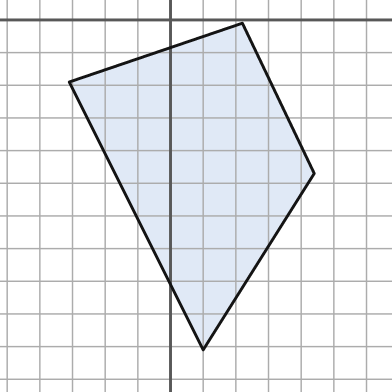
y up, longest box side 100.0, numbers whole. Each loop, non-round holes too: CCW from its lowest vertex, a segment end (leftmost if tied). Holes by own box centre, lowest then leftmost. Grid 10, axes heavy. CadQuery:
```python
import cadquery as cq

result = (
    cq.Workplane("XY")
    .moveTo(10.0, -101.0)
    .lineTo(44.0, -47.0)
    .lineTo(22.0, -1.0)
    .lineTo(-31.0, -19.0)
    .close()
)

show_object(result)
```